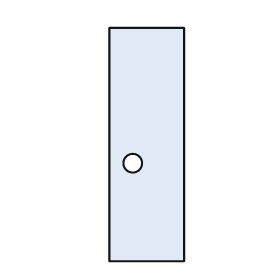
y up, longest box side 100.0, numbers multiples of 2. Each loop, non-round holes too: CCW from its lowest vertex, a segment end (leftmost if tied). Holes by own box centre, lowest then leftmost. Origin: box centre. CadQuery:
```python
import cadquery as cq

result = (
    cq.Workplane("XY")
    .moveTo(-16.0, -50.0)
    .lineTo(16.0, -50.0)
    .lineTo(16.0, 50.0)
    .lineTo(-16.0, 50.0)
    .close()
    .moveTo(-6.0, -8.0)
    .circle(4.0)
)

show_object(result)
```